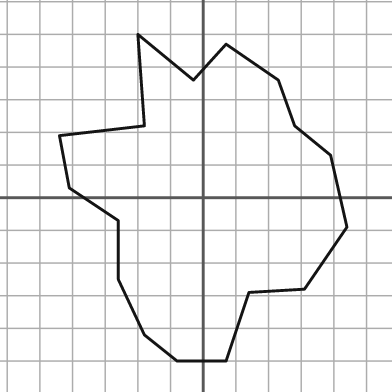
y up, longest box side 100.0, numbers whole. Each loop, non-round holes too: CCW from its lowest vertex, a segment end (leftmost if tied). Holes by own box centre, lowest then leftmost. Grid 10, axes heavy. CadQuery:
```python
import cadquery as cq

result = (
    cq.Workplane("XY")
    .moveTo(-8.0, -50.0)
    .lineTo(7.0, -50.0)
    .lineTo(14.0, -29.0)
    .lineTo(31.0, -28.0)
    .lineTo(44.0, -9.0)
    .lineTo(39.0, 13.0)
    .lineTo(28.0, 22.0)
    .lineTo(23.0, 36.0)
    .lineTo(7.0, 47.0)
    .lineTo(-3.0, 36.0)
    .lineTo(-20.0, 50.0)
    .lineTo(-18.0, 22.0)
    .lineTo(-44.0, 19.0)
    .lineTo(-41.0, 3.0)
    .lineTo(-26.0, -7.0)
    .lineTo(-26.0, -25.0)
    .lineTo(-18.0, -42.0)
    .close()
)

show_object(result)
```